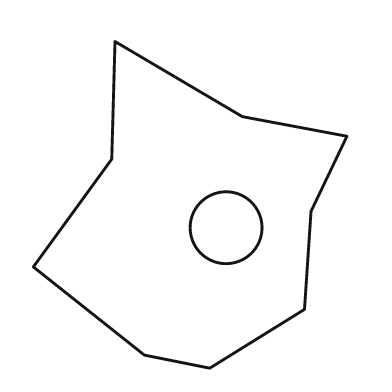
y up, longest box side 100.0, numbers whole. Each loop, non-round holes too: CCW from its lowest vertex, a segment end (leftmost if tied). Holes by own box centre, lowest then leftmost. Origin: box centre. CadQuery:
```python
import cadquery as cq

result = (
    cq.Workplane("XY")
    .moveTo(6.0, -50.0)
    .lineTo(35.0, -32.0)
    .lineTo(37.0, -2.0)
    .lineTo(48.0, 21.0)
    .lineTo(16.0, 27.0)
    .lineTo(-23.0, 50.0)
    .lineTo(-24.0, 14.0)
    .lineTo(-48.0, -19.0)
    .lineTo(-14.0, -46.0)
    .close()
    .moveTo(11.0, -7.0)
    .circle(11.0)
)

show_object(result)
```